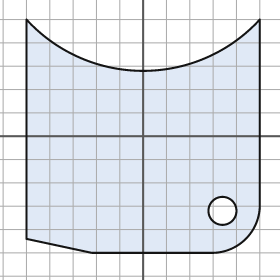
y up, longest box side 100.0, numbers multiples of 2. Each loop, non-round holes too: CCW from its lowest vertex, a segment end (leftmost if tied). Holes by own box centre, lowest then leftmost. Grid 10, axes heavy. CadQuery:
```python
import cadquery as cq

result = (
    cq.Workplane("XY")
    .moveTo(-22.0, -50.0)
    .lineTo(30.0, -50.0)
    .threePointArc((44.0, -44.0), (50.0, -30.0))
    .lineTo(50.0, 50.0)
    .threePointArc((0.0, 28.0), (-50.0, 50.0))
    .lineTo(-50.0, -44.0)
    .close()
    .moveTo(34.0, -32.0)
    .circle(6.0)
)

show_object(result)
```